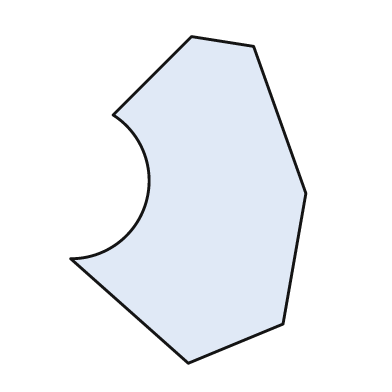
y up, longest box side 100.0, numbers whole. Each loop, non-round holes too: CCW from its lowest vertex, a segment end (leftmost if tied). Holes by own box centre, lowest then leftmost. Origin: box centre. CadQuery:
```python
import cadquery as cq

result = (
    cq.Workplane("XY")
    .moveTo(0.0, -50.0)
    .lineTo(29.0, -38.0)
    .lineTo(36.0, 2.0)
    .lineTo(20.0, 47.0)
    .lineTo(1.0, 50.0)
    .lineTo(-23.0, 26.0)
    .threePointArc((-13.0, -1.0), (-36.0, -18.0))
    .close()
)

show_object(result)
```